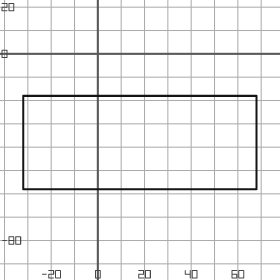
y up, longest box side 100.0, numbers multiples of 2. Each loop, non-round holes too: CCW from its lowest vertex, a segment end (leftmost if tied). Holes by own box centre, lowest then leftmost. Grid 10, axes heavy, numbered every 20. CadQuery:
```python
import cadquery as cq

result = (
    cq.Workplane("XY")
    .moveTo(-32.0, -58.0)
    .lineTo(68.0, -58.0)
    .lineTo(68.0, -18.0)
    .lineTo(-32.0, -18.0)
    .close()
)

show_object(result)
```